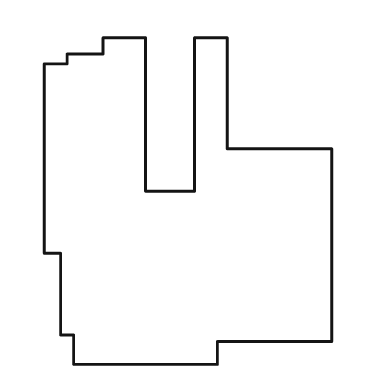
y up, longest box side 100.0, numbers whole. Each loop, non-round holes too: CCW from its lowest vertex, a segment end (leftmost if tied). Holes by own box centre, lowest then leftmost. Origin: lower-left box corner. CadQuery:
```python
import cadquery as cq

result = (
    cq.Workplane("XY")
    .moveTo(9.0, 0.0)
    .lineTo(53.0, 0.0)
    .lineTo(53.0, 7.0)
    .lineTo(88.0, 7.0)
    .lineTo(88.0, 66.0)
    .lineTo(56.0, 66.0)
    .lineTo(56.0, 100.0)
    .lineTo(46.0, 100.0)
    .lineTo(46.0, 53.0)
    .lineTo(31.0, 53.0)
    .lineTo(31.0, 100.0)
    .lineTo(18.0, 100.0)
    .lineTo(18.0, 95.0)
    .lineTo(7.0, 95.0)
    .lineTo(7.0, 92.0)
    .lineTo(0.0, 92.0)
    .lineTo(0.0, 34.0)
    .lineTo(5.0, 34.0)
    .lineTo(5.0, 9.0)
    .lineTo(9.0, 9.0)
    .close()
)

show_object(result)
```